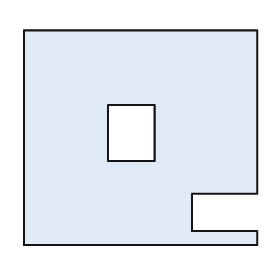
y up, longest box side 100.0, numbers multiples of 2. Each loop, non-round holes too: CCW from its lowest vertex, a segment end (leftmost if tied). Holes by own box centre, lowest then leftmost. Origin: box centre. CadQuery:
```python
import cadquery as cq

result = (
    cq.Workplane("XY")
    .moveTo(-50.0, -46.0)
    .lineTo(50.0, -46.0)
    .lineTo(50.0, -40.0)
    .lineTo(22.0, -40.0)
    .lineTo(22.0, -24.0)
    .lineTo(50.0, -24.0)
    .lineTo(50.0, 46.0)
    .lineTo(-50.0, 46.0)
    .close()
    .moveTo(-14.0, -10.0)
    .lineTo(6.0, -10.0)
    .lineTo(6.0, 14.0)
    .lineTo(-14.0, 14.0)
    .close()
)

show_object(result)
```